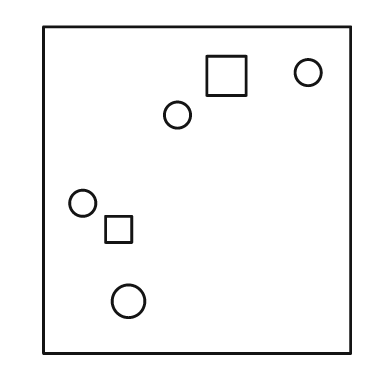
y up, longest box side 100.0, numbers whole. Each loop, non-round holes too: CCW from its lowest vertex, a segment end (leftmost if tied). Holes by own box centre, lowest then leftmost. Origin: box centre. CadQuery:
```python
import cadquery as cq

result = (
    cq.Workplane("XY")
    .moveTo(-47.0, -50.0)
    .lineTo(47.0, -50.0)
    .lineTo(47.0, 50.0)
    .lineTo(-47.0, 50.0)
    .close()
    .moveTo(-21.0, -34.0)
    .circle(5.0)
    .moveTo(-28.0, -16.0)
    .lineTo(-20.0, -16.0)
    .lineTo(-20.0, -8.0)
    .lineTo(-28.0, -8.0)
    .close()
    .moveTo(-35.0, -4.0)
    .circle(4.0)
    .moveTo(-6.0, 23.0)
    .circle(4.0)
    .moveTo(3.0, 29.0)
    .lineTo(15.0, 29.0)
    .lineTo(15.0, 41.0)
    .lineTo(3.0, 41.0)
    .close()
    .moveTo(34.0, 36.0)
    .circle(4.0)
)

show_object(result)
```